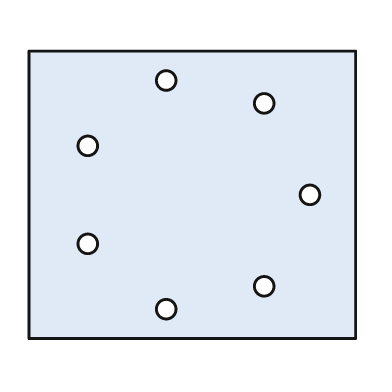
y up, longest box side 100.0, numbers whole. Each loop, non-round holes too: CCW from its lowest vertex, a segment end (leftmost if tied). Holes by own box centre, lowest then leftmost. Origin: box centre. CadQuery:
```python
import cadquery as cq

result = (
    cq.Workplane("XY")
    .moveTo(-50.0, -44.0)
    .lineTo(50.0, -44.0)
    .lineTo(50.0, 44.0)
    .lineTo(-50.0, 44.0)
    .close()
    .moveTo(-8.0, -35.0)
    .circle(3.0)
    .moveTo(22.0, -28.0)
    .circle(3.0)
    .moveTo(-32.0, -15.0)
    .circle(3.0)
    .moveTo(36.0, 0.0)
    .circle(3.0)
    .moveTo(-32.0, 15.0)
    .circle(3.0)
    .moveTo(22.0, 28.0)
    .circle(3.0)
    .moveTo(-8.0, 35.0)
    .circle(3.0)
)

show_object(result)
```